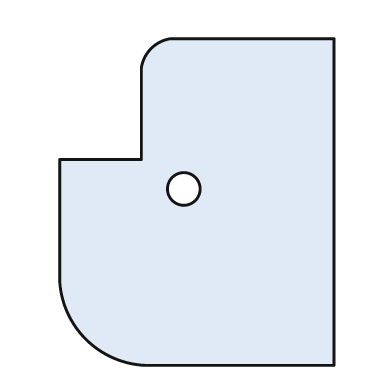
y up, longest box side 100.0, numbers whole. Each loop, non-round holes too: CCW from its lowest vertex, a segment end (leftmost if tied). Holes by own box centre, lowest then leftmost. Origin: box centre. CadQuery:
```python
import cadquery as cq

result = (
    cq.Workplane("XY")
    .moveTo(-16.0, -50.0)
    .lineTo(42.0, -50.0)
    .lineTo(42.0, 50.0)
    .lineTo(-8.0, 50.0)
    .threePointArc((-14.0, 47.0), (-17.0, 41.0))
    .lineTo(-17.0, 13.0)
    .lineTo(-42.0, 13.0)
    .lineTo(-42.0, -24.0)
    .threePointArc((-34.0, -42.0), (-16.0, -50.0))
    .close()
    .moveTo(-4.0, 4.0)
    .circle(5.0)
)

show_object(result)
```